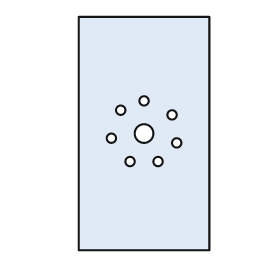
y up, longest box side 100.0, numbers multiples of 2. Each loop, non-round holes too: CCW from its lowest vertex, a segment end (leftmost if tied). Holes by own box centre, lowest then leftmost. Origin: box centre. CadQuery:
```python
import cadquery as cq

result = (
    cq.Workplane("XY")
    .moveTo(-28.0, -50.0)
    .lineTo(28.0, -50.0)
    .lineTo(28.0, 50.0)
    .lineTo(-28.0, 50.0)
    .close()
    .moveTo(-6.0, -12.0)
    .circle(2.0)
    .moveTo(6.0, -12.0)
    .circle(2.0)
    .moveTo(14.0, -4.0)
    .circle(2.0)
    .moveTo(-14.0, -2.0)
    .circle(2.0)
    .moveTo(0.0, 0.0)
    .circle(4.0)
    .moveTo(12.0, 8.0)
    .circle(2.0)
    .moveTo(-10.0, 10.0)
    .circle(2.0)
    .moveTo(0.0, 14.0)
    .circle(2.0)
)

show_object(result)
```